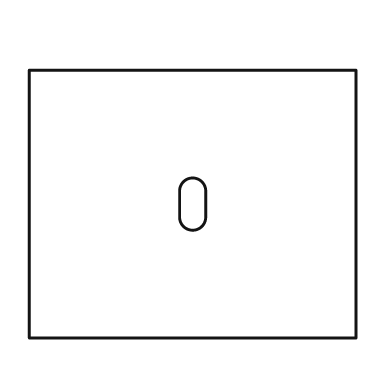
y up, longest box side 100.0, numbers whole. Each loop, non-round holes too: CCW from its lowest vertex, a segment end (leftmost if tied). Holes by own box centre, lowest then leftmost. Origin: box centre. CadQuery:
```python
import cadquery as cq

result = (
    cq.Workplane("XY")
    .moveTo(-50.0, -41.0)
    .lineTo(50.0, -41.0)
    .lineTo(50.0, 41.0)
    .lineTo(-50.0, 41.0)
    .close()
    .moveTo(-4.0, -4.0)
    .threePointArc((0.0, -8.0), (4.0, -4.0))
    .lineTo(4.0, 4.0)
    .threePointArc((0.0, 8.0), (-4.0, 4.0))
    .close()
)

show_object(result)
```